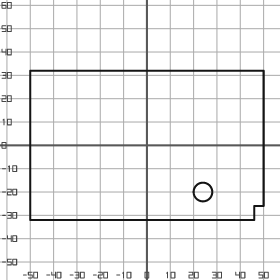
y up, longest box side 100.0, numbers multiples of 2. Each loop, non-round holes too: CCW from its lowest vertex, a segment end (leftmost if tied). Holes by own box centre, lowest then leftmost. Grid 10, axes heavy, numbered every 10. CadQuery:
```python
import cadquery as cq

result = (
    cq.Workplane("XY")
    .moveTo(-50.0, -32.0)
    .lineTo(46.0, -32.0)
    .lineTo(46.0, -26.0)
    .lineTo(50.0, -26.0)
    .lineTo(50.0, 32.0)
    .lineTo(-50.0, 32.0)
    .close()
    .moveTo(24.0, -20.0)
    .circle(4.0)
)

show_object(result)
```